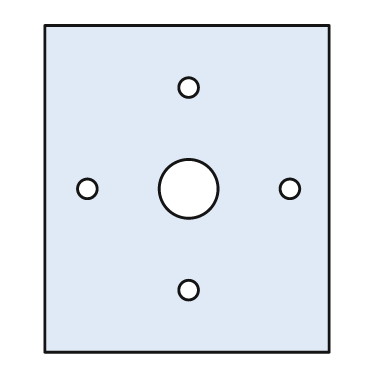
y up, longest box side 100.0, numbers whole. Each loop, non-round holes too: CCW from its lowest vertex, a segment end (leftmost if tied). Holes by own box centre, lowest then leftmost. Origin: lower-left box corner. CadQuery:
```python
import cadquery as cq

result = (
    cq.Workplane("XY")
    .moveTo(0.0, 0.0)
    .lineTo(87.0, 0.0)
    .lineTo(87.0, 100.0)
    .lineTo(0.0, 100.0)
    .close()
    .moveTo(44.0, 19.0)
    .circle(3.0)
    .moveTo(13.0, 50.0)
    .circle(3.0)
    .moveTo(44.0, 50.0)
    .circle(9.0)
    .moveTo(75.0, 50.0)
    .circle(3.0)
    .moveTo(44.0, 81.0)
    .circle(3.0)
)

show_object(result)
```